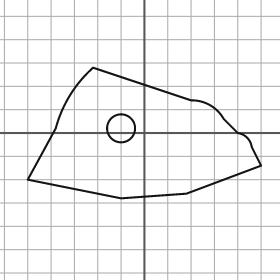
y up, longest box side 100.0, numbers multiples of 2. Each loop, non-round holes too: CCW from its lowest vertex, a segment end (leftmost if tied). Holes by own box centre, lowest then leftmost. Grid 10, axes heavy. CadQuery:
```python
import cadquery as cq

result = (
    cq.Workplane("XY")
    .moveTo(-10.0, -28.0)
    .lineTo(18.0, -26.0)
    .lineTo(50.0, -14.0)
    .lineTo(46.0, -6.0)
    .threePointArc((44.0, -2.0), (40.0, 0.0))
    .lineTo(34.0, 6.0)
    .threePointArc((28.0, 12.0), (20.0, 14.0))
    .lineTo(-22.0, 28.0)
    .threePointArc((-32.0, 16.0), (-38.0, 2.0))
    .lineTo(-50.0, -20.0)
    .close()
    .moveTo(-10.0, 2.0)
    .circle(6.0)
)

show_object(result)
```